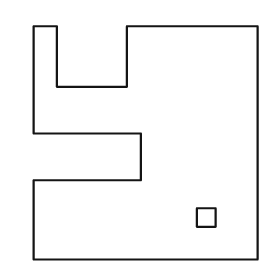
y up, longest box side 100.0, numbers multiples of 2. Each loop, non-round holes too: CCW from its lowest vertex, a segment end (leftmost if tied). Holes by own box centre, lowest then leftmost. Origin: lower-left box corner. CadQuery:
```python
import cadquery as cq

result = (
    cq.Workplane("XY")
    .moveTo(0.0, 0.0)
    .lineTo(96.0, 0.0)
    .lineTo(96.0, 100.0)
    .lineTo(40.0, 100.0)
    .lineTo(40.0, 74.0)
    .lineTo(10.0, 74.0)
    .lineTo(10.0, 100.0)
    .lineTo(0.0, 100.0)
    .lineTo(0.0, 54.0)
    .lineTo(46.0, 54.0)
    .lineTo(46.0, 34.0)
    .lineTo(0.0, 34.0)
    .close()
    .moveTo(70.0, 14.0)
    .lineTo(78.0, 14.0)
    .lineTo(78.0, 22.0)
    .lineTo(70.0, 22.0)
    .close()
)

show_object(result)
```